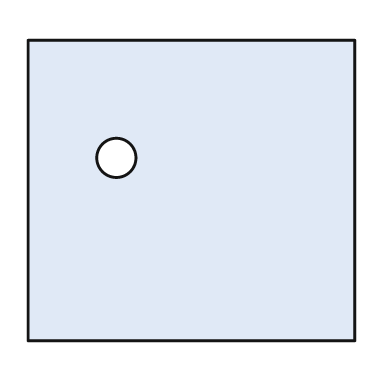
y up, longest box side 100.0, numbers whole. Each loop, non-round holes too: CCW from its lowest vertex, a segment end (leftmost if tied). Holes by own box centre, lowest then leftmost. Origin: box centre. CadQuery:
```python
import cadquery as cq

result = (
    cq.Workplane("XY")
    .moveTo(-50.0, -46.0)
    .lineTo(50.0, -46.0)
    .lineTo(50.0, 46.0)
    .lineTo(-50.0, 46.0)
    .close()
    .moveTo(-23.0, 10.0)
    .circle(6.0)
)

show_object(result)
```